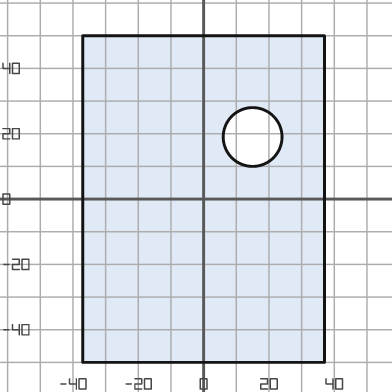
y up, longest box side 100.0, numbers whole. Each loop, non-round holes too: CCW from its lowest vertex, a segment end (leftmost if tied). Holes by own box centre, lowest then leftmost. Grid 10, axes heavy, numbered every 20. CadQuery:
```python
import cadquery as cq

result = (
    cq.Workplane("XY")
    .moveTo(-37.0, -50.0)
    .lineTo(37.0, -50.0)
    .lineTo(37.0, 50.0)
    .lineTo(-37.0, 50.0)
    .close()
    .moveTo(15.0, 19.0)
    .circle(9.0)
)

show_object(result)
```